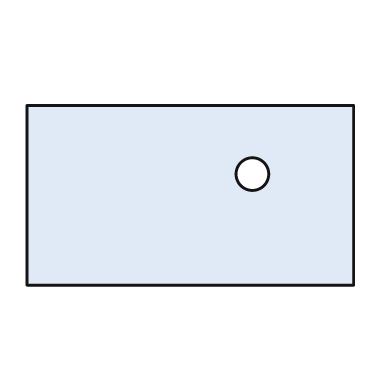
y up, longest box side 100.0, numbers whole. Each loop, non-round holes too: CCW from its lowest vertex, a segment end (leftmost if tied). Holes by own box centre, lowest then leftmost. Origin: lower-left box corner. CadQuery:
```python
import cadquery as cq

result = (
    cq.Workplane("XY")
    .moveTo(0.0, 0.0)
    .lineTo(100.0, 0.0)
    .lineTo(100.0, 55.0)
    .lineTo(0.0, 55.0)
    .close()
    .moveTo(69.0, 34.0)
    .circle(5.0)
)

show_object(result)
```